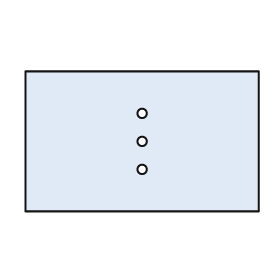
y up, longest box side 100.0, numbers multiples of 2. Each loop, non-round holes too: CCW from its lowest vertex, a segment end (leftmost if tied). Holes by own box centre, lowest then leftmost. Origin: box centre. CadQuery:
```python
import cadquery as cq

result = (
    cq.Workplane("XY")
    .moveTo(-50.0, -30.0)
    .lineTo(50.0, -30.0)
    .lineTo(50.0, 30.0)
    .lineTo(-50.0, 30.0)
    .close()
    .moveTo(0.0, -12.0)
    .circle(2.0)
    .moveTo(0.0, 0.0)
    .circle(2.0)
    .moveTo(0.0, 12.0)
    .circle(2.0)
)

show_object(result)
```